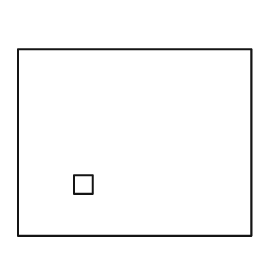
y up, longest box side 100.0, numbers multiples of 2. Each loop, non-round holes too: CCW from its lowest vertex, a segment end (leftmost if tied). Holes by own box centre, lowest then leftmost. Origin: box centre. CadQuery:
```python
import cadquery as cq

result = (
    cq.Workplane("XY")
    .moveTo(-50.0, -40.0)
    .lineTo(50.0, -40.0)
    .lineTo(50.0, 40.0)
    .lineTo(-50.0, 40.0)
    .close()
    .moveTo(-26.0, -22.0)
    .lineTo(-18.0, -22.0)
    .lineTo(-18.0, -14.0)
    .lineTo(-26.0, -14.0)
    .close()
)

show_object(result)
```